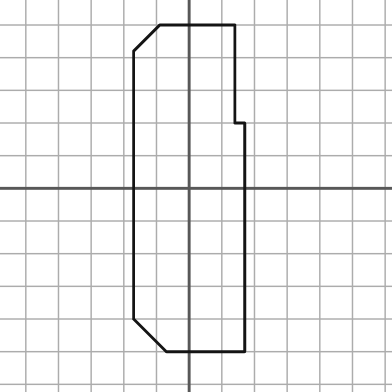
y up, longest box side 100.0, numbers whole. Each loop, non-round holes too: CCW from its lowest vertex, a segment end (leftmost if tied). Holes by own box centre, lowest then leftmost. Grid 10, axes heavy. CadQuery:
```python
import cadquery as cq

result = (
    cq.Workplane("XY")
    .moveTo(-7.0, -50.0)
    .lineTo(17.0, -50.0)
    .lineTo(17.0, 20.0)
    .lineTo(14.0, 20.0)
    .lineTo(14.0, 50.0)
    .lineTo(-9.0, 50.0)
    .lineTo(-17.0, 42.0)
    .lineTo(-17.0, -40.0)
    .close()
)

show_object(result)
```